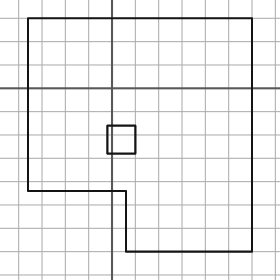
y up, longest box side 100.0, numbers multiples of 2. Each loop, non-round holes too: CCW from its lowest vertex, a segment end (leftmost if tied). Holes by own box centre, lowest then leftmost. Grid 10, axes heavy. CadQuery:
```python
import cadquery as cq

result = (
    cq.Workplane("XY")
    .moveTo(6.0, -70.0)
    .lineTo(60.0, -70.0)
    .lineTo(60.0, 30.0)
    .lineTo(-36.0, 30.0)
    .lineTo(-36.0, -44.0)
    .lineTo(6.0, -44.0)
    .close()
    .moveTo(-2.0, -28.0)
    .lineTo(10.0, -28.0)
    .lineTo(10.0, -16.0)
    .lineTo(-2.0, -16.0)
    .close()
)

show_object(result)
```